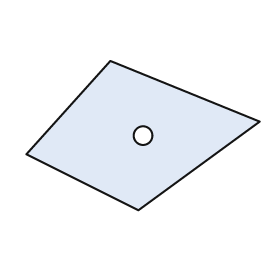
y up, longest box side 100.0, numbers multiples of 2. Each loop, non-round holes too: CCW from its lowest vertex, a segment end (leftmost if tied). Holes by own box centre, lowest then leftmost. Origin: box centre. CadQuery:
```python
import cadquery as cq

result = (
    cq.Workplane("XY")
    .moveTo(-2.0, -32.0)
    .lineTo(50.0, 6.0)
    .lineTo(-14.0, 32.0)
    .lineTo(-50.0, -8.0)
    .close()
    .moveTo(0.0, 0.0)
    .circle(4.0)
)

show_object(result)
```